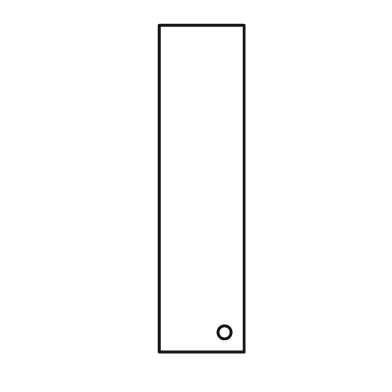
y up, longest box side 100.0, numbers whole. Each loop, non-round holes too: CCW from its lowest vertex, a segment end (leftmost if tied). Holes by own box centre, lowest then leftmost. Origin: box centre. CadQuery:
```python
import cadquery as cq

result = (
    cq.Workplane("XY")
    .moveTo(-13.0, -50.0)
    .lineTo(13.0, -50.0)
    .lineTo(13.0, 50.0)
    .lineTo(-13.0, 50.0)
    .close()
    .moveTo(7.0, -44.0)
    .circle(2.0)
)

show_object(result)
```